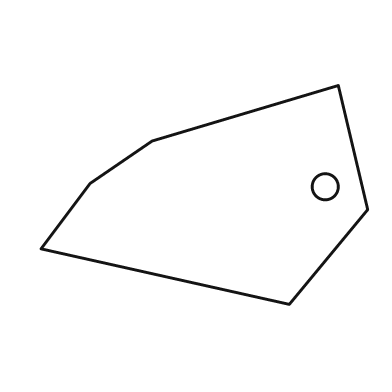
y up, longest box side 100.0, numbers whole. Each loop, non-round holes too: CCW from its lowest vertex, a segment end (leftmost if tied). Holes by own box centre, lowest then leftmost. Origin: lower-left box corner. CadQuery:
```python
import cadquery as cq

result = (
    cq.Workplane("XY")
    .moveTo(76.0, 0.0)
    .lineTo(100.0, 29.0)
    .lineTo(91.0, 67.0)
    .lineTo(34.0, 50.0)
    .lineTo(15.0, 37.0)
    .lineTo(0.0, 17.0)
    .close()
    .moveTo(87.0, 36.0)
    .circle(4.0)
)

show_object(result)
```